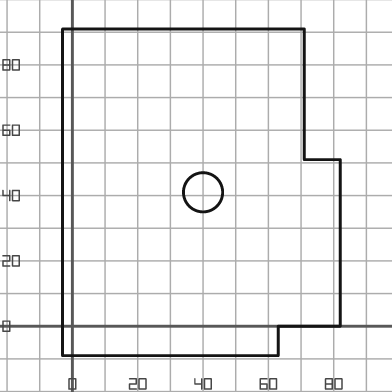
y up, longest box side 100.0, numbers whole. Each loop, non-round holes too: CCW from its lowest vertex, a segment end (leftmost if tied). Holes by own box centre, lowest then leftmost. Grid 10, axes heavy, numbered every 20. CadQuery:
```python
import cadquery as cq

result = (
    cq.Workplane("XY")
    .moveTo(-3.0, -9.0)
    .lineTo(63.0, -9.0)
    .lineTo(63.0, 0.0)
    .lineTo(82.0, 0.0)
    .lineTo(82.0, 51.0)
    .lineTo(71.0, 51.0)
    .lineTo(71.0, 91.0)
    .lineTo(-3.0, 91.0)
    .close()
    .moveTo(40.0, 41.0)
    .circle(6.0)
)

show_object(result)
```